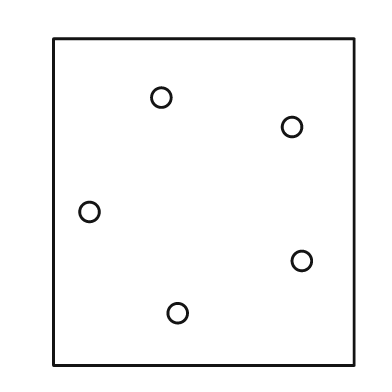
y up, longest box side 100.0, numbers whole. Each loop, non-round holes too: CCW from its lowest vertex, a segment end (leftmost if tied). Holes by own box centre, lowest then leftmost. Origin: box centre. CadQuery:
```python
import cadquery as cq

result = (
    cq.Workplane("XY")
    .moveTo(-46.0, -50.0)
    .lineTo(46.0, -50.0)
    .lineTo(46.0, 50.0)
    .lineTo(-46.0, 50.0)
    .close()
    .moveTo(-8.0, -34.0)
    .circle(3.0)
    .moveTo(30.0, -18.0)
    .circle(3.0)
    .moveTo(-35.0, -3.0)
    .circle(3.0)
    .moveTo(27.0, 23.0)
    .circle(3.0)
    .moveTo(-13.0, 32.0)
    .circle(3.0)
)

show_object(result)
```